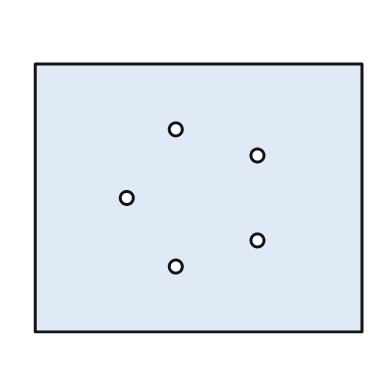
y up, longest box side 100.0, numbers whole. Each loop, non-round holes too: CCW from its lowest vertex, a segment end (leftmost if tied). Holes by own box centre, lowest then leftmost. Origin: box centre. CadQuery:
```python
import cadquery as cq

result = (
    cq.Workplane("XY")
    .moveTo(-50.0, -41.0)
    .lineTo(50.0, -41.0)
    .lineTo(50.0, 41.0)
    .lineTo(-50.0, 41.0)
    .close()
    .moveTo(-7.0, -21.0)
    .circle(2.0)
    .moveTo(18.0, -13.0)
    .circle(2.0)
    .moveTo(-22.0, 0.0)
    .circle(2.0)
    .moveTo(18.0, 13.0)
    .circle(2.0)
    .moveTo(-7.0, 21.0)
    .circle(2.0)
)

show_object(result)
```